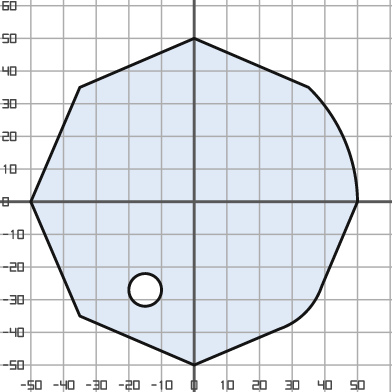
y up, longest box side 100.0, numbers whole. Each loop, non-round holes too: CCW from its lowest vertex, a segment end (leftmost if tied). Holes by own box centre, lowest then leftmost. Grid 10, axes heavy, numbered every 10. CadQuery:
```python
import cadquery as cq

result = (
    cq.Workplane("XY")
    .moveTo(0.0, -50.0)
    .lineTo(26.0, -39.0)
    .threePointArc((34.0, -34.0), (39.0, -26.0))
    .lineTo(50.0, 0.0)
    .threePointArc((46.0, 19.0), (35.0, 35.0))
    .lineTo(0.0, 50.0)
    .lineTo(-35.0, 35.0)
    .lineTo(-50.0, 0.0)
    .lineTo(-35.0, -35.0)
    .close()
    .moveTo(-15.0, -27.0)
    .circle(5.0)
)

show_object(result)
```